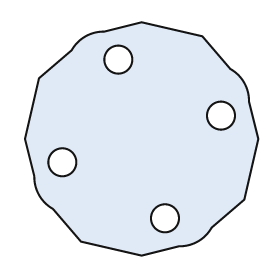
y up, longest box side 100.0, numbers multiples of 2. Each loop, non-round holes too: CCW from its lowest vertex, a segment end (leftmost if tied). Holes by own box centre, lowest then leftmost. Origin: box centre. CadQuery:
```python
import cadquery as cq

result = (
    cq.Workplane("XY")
    .moveTo(0.0, -50.0)
    .lineTo(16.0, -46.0)
    .threePointArc((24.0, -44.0), (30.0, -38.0))
    .lineTo(44.0, -26.0)
    .lineTo(50.0, 0.0)
    .lineTo(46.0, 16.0)
    .threePointArc((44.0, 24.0), (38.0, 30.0))
    .lineTo(26.0, 44.0)
    .lineTo(0.0, 50.0)
    .lineTo(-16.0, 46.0)
    .threePointArc((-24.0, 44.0), (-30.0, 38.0))
    .lineTo(-44.0, 26.0)
    .lineTo(-50.0, 0.0)
    .lineTo(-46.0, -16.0)
    .threePointArc((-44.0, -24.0), (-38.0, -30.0))
    .lineTo(-26.0, -44.0)
    .close()
    .moveTo(10.0, -34.0)
    .circle(6.0)
    .moveTo(-34.0, -10.0)
    .circle(6.0)
    .moveTo(34.0, 10.0)
    .circle(6.0)
    .moveTo(-10.0, 34.0)
    .circle(6.0)
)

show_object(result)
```